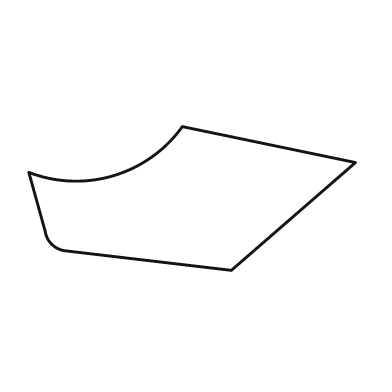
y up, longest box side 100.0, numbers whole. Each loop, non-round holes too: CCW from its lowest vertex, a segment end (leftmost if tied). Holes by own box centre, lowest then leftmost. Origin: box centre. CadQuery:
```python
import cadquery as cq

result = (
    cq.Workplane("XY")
    .moveTo(12.0, -22.0)
    .lineTo(50.0, 11.0)
    .lineTo(-3.0, 22.0)
    .threePointArc((-24.0, 7.0), (-50.0, 8.0))
    .lineTo(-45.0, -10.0)
    .threePointArc((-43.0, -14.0), (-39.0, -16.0))
    .close()
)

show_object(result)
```